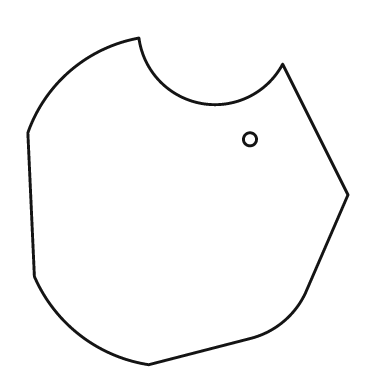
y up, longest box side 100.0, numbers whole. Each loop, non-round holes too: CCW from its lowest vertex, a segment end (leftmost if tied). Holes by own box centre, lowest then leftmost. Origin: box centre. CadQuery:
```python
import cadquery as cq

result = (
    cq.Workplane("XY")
    .moveTo(-12.0, -50.0)
    .lineTo(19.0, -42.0)
    .threePointArc((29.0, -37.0), (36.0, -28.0))
    .lineTo(49.0, 2.0)
    .lineTo(29.0, 42.0)
    .threePointArc((4.0, 30.0), (-15.0, 50.0))
    .threePointArc((-36.0, 40.0), (-49.0, 21.0))
    .lineTo(-47.0, -23.0)
    .threePointArc((-33.0, -41.0), (-12.0, -50.0))
    .close()
    .moveTo(19.0, 19.0)
    .circle(2.0)
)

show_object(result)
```